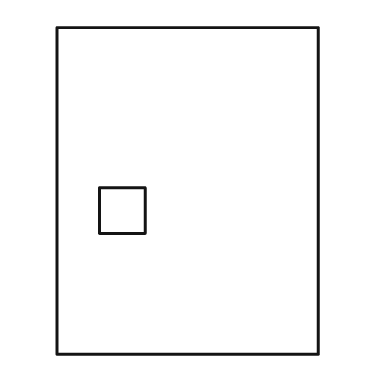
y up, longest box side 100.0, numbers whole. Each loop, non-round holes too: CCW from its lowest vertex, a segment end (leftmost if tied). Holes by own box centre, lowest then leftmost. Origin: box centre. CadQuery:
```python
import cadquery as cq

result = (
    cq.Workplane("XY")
    .moveTo(-40.0, -50.0)
    .lineTo(40.0, -50.0)
    .lineTo(40.0, 50.0)
    .lineTo(-40.0, 50.0)
    .close()
    .moveTo(-27.0, -13.0)
    .lineTo(-13.0, -13.0)
    .lineTo(-13.0, 1.0)
    .lineTo(-27.0, 1.0)
    .close()
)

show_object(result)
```